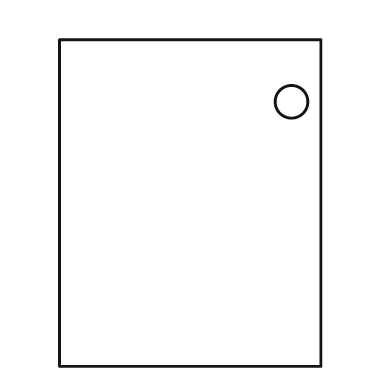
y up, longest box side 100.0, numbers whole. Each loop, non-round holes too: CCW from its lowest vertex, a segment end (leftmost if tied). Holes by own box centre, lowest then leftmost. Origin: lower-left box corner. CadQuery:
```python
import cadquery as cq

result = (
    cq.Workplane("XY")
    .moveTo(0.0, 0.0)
    .lineTo(80.0, 0.0)
    .lineTo(80.0, 100.0)
    .lineTo(0.0, 100.0)
    .close()
    .moveTo(71.0, 81.0)
    .circle(5.0)
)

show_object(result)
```